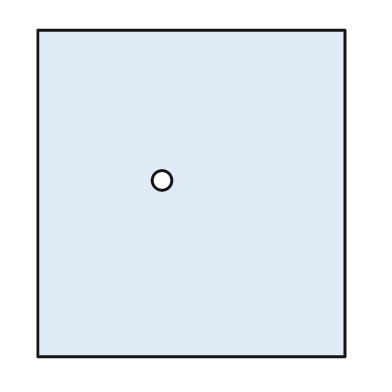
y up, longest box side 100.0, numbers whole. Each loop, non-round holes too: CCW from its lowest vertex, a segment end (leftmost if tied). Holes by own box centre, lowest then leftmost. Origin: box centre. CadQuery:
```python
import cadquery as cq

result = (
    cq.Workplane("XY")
    .moveTo(-47.0, -50.0)
    .lineTo(47.0, -50.0)
    .lineTo(47.0, 50.0)
    .lineTo(-47.0, 50.0)
    .close()
    .moveTo(-9.0, 4.0)
    .circle(3.0)
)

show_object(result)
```